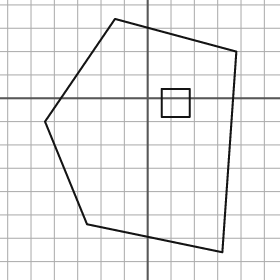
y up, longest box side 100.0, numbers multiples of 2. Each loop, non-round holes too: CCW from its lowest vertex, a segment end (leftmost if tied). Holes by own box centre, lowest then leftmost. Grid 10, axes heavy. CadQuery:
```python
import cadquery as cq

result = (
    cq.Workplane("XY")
    .moveTo(32.0, -66.0)
    .lineTo(38.0, 20.0)
    .lineTo(-14.0, 34.0)
    .lineTo(-44.0, -10.0)
    .lineTo(-26.0, -54.0)
    .close()
    .moveTo(6.0, -8.0)
    .lineTo(18.0, -8.0)
    .lineTo(18.0, 4.0)
    .lineTo(6.0, 4.0)
    .close()
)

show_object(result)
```